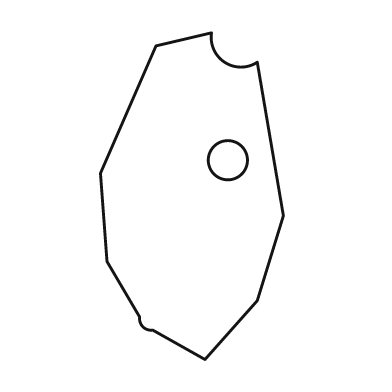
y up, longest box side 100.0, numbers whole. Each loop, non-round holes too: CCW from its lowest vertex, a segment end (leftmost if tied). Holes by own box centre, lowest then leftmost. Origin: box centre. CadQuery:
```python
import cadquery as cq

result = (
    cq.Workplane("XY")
    .moveTo(4.0, -50.0)
    .lineTo(20.0, -32.0)
    .lineTo(28.0, -6.0)
    .lineTo(20.0, 41.0)
    .threePointArc((10.0, 41.0), (6.0, 50.0))
    .lineTo(-11.0, 46.0)
    .lineTo(-28.0, 7.0)
    .lineTo(-26.0, -20.0)
    .lineTo(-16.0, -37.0)
    .threePointArc((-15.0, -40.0), (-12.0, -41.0))
    .close()
    .moveTo(11.0, 11.0)
    .circle(6.0)
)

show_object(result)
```